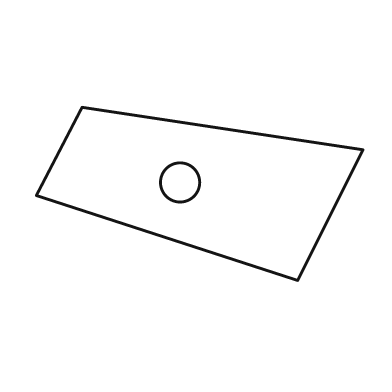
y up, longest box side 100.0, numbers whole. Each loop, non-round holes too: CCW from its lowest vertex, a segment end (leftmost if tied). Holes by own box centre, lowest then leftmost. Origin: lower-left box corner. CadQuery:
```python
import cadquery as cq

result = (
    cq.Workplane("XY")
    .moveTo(80.0, 0.0)
    .lineTo(100.0, 40.0)
    .lineTo(14.0, 53.0)
    .lineTo(0.0, 26.0)
    .close()
    .moveTo(44.0, 30.0)
    .circle(6.0)
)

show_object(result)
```